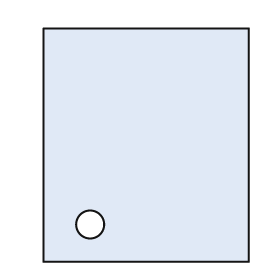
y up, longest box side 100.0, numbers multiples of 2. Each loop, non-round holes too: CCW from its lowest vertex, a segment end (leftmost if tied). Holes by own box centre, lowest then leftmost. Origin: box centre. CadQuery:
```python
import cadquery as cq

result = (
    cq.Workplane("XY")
    .moveTo(-44.0, -50.0)
    .lineTo(44.0, -50.0)
    .lineTo(44.0, 50.0)
    .lineTo(-44.0, 50.0)
    .close()
    .moveTo(-24.0, -34.0)
    .circle(6.0)
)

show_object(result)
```